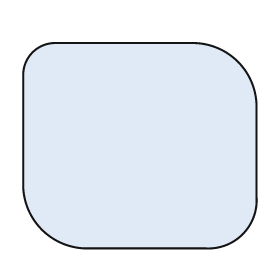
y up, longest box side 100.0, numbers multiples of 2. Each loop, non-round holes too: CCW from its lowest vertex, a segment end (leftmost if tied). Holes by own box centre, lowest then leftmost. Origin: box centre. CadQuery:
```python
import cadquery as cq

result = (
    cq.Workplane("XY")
    .moveTo(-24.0, -44.0)
    .lineTo(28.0, -44.0)
    .threePointArc((44.0, -38.0), (50.0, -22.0))
    .lineTo(50.0, 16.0)
    .threePointArc((42.0, 36.0), (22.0, 44.0))
    .lineTo(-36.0, 44.0)
    .threePointArc((-46.0, 40.0), (-50.0, 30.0))
    .lineTo(-50.0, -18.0)
    .threePointArc((-42.0, -36.0), (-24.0, -44.0))
    .close()
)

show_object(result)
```